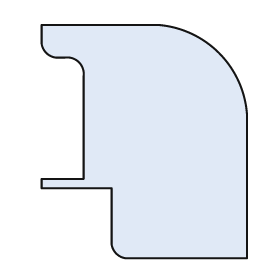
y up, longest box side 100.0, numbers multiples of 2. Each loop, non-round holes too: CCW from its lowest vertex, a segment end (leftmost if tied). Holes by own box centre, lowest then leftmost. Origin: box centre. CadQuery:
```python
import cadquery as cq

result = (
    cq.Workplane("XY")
    .moveTo(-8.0, -50.0)
    .lineTo(44.0, -50.0)
    .lineTo(44.0, 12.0)
    .threePointArc((32.0, 38.0), (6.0, 50.0))
    .lineTo(-44.0, 50.0)
    .lineTo(-44.0, 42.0)
    .threePointArc((-42.0, 38.0), (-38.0, 36.0))
    .lineTo(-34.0, 36.0)
    .threePointArc((-28.0, 34.0), (-26.0, 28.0))
    .lineTo(-26.0, -16.0)
    .lineTo(-44.0, -16.0)
    .lineTo(-44.0, -20.0)
    .lineTo(-14.0, -20.0)
    .lineTo(-14.0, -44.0)
    .threePointArc((-12.0, -48.0), (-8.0, -50.0))
    .close()
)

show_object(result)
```